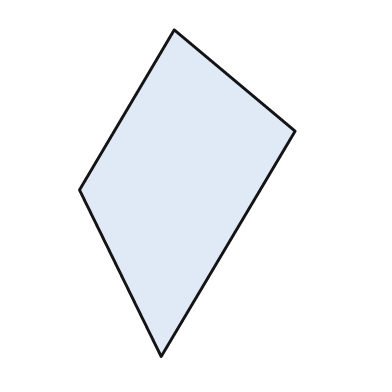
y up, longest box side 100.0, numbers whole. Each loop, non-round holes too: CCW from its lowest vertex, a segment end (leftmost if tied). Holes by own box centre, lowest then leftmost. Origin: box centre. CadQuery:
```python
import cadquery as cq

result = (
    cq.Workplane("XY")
    .moveTo(-8.0, -50.0)
    .lineTo(33.0, 19.0)
    .lineTo(-4.0, 50.0)
    .lineTo(-33.0, 1.0)
    .close()
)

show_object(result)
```